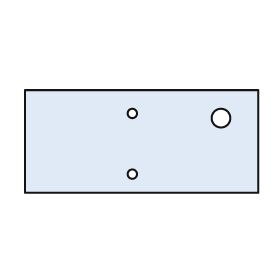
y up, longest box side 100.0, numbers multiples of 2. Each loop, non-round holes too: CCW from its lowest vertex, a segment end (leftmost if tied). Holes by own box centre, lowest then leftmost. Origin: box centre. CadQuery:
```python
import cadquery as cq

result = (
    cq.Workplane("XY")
    .moveTo(-50.0, -22.0)
    .lineTo(50.0, -22.0)
    .lineTo(50.0, 22.0)
    .lineTo(-50.0, 22.0)
    .close()
    .moveTo(-4.0, -14.0)
    .circle(2.0)
    .moveTo(34.0, 10.0)
    .circle(4.0)
    .moveTo(-4.0, 12.0)
    .circle(2.0)
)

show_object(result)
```